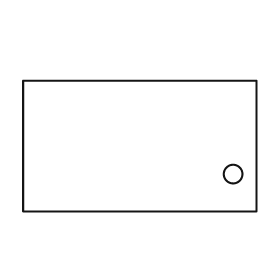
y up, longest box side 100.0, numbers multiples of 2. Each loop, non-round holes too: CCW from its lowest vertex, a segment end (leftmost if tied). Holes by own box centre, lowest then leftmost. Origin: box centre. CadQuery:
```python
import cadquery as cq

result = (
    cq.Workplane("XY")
    .moveTo(-50.0, -28.0)
    .lineTo(50.0, -28.0)
    .lineTo(50.0, 28.0)
    .lineTo(-50.0, 28.0)
    .close()
    .moveTo(40.0, -12.0)
    .circle(4.0)
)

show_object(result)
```